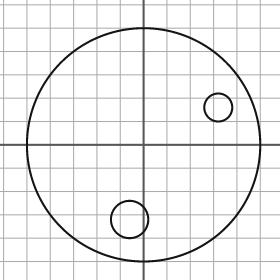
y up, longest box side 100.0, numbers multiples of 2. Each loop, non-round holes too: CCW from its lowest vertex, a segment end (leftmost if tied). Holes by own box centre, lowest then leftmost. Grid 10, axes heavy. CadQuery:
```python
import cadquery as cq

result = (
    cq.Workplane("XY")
    .moveTo(0.0, 0.0)
    .circle(50.0)
    .moveTo(-6.0, -32.0)
    .circle(8.0)
    .moveTo(32.0, 16.0)
    .circle(6.0)
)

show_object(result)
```